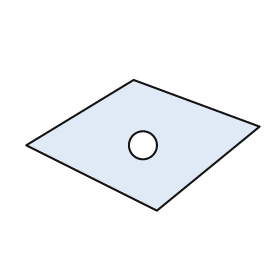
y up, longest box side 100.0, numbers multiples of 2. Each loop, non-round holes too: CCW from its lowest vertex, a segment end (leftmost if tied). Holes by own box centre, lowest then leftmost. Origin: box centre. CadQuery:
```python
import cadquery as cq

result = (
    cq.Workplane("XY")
    .moveTo(6.0, -28.0)
    .lineTo(50.0, 8.0)
    .lineTo(-4.0, 28.0)
    .lineTo(-50.0, 0.0)
    .close()
    .moveTo(0.0, 0.0)
    .circle(6.0)
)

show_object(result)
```